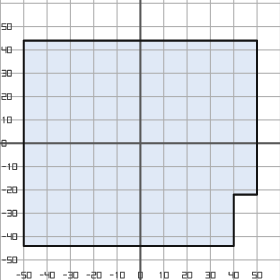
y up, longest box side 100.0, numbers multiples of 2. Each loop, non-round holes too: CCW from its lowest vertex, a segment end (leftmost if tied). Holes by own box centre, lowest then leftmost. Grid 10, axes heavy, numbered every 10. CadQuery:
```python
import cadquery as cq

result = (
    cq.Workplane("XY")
    .moveTo(-50.0, -44.0)
    .lineTo(40.0, -44.0)
    .lineTo(40.0, -22.0)
    .lineTo(50.0, -22.0)
    .lineTo(50.0, 44.0)
    .lineTo(-50.0, 44.0)
    .close()
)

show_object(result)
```